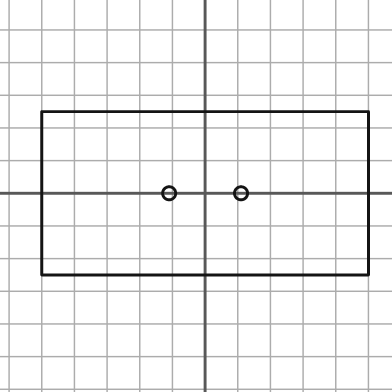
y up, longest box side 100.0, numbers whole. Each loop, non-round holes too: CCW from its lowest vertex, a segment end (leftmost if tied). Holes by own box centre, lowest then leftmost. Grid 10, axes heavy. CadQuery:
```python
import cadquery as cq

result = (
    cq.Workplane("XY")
    .moveTo(-50.0, -25.0)
    .lineTo(50.0, -25.0)
    .lineTo(50.0, 25.0)
    .lineTo(-50.0, 25.0)
    .close()
    .moveTo(-11.0, 0.0)
    .circle(2.0)
    .moveTo(11.0, 0.0)
    .circle(2.0)
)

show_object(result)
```